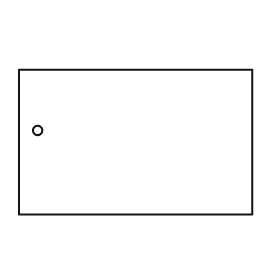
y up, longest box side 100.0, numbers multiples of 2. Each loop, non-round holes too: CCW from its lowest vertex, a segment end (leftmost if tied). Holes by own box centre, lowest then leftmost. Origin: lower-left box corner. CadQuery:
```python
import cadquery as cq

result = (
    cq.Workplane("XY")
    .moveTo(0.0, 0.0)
    .lineTo(100.0, 0.0)
    .lineTo(100.0, 62.0)
    .lineTo(0.0, 62.0)
    .close()
    .moveTo(8.0, 36.0)
    .circle(2.0)
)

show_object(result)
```